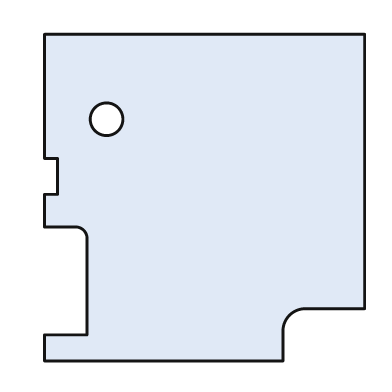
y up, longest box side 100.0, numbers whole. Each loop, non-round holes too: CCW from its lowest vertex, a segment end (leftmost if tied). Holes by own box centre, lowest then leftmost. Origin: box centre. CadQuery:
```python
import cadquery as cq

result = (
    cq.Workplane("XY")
    .moveTo(-49.0, -50.0)
    .lineTo(24.0, -50.0)
    .lineTo(24.0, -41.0)
    .threePointArc((26.0, -36.0), (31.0, -34.0))
    .lineTo(49.0, -34.0)
    .lineTo(49.0, 50.0)
    .lineTo(-49.0, 50.0)
    .lineTo(-49.0, 12.0)
    .lineTo(-45.0, 12.0)
    .lineTo(-45.0, 1.0)
    .lineTo(-49.0, 1.0)
    .lineTo(-49.0, -9.0)
    .lineTo(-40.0, -9.0)
    .threePointArc((-37.0, -10.0), (-36.0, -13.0))
    .lineTo(-36.0, -42.0)
    .lineTo(-49.0, -42.0)
    .close()
    .moveTo(-30.0, 24.0)
    .circle(5.0)
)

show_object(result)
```